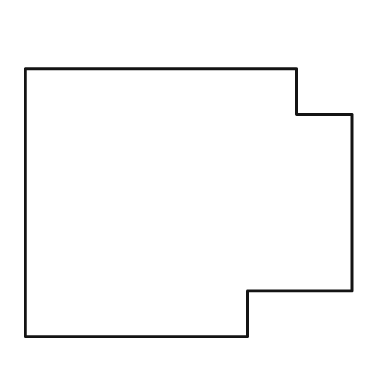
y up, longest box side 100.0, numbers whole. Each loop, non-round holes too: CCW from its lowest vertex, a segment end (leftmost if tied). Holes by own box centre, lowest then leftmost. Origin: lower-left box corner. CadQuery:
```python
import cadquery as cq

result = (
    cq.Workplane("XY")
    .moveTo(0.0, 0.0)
    .lineTo(68.0, 0.0)
    .lineTo(68.0, 14.0)
    .lineTo(100.0, 14.0)
    .lineTo(100.0, 68.0)
    .lineTo(83.0, 68.0)
    .lineTo(83.0, 82.0)
    .lineTo(0.0, 82.0)
    .close()
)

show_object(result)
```